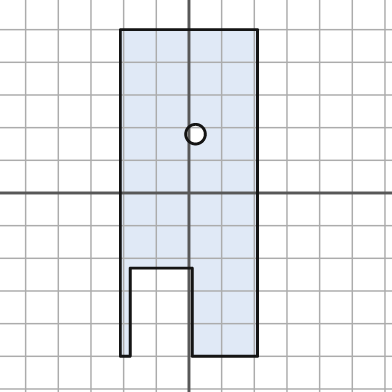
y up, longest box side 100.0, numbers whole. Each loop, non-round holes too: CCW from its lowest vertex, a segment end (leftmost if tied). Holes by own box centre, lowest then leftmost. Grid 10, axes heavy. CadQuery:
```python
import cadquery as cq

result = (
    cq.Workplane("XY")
    .moveTo(-21.0, -50.0)
    .lineTo(-18.0, -50.0)
    .lineTo(-18.0, -23.0)
    .lineTo(1.0, -23.0)
    .lineTo(1.0, -50.0)
    .lineTo(21.0, -50.0)
    .lineTo(21.0, 50.0)
    .lineTo(-21.0, 50.0)
    .close()
    .moveTo(2.0, 18.0)
    .circle(3.0)
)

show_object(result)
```